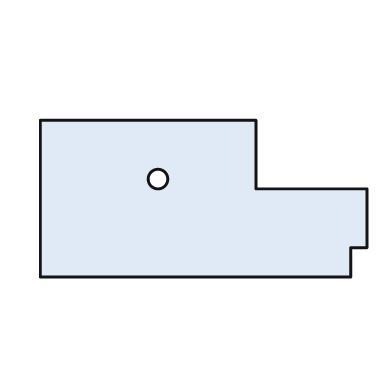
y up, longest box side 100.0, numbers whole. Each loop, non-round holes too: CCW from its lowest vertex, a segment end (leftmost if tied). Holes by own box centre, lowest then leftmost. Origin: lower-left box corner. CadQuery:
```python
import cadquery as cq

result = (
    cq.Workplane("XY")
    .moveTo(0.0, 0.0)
    .lineTo(95.0, 0.0)
    .lineTo(95.0, 9.0)
    .lineTo(100.0, 9.0)
    .lineTo(100.0, 27.0)
    .lineTo(66.0, 27.0)
    .lineTo(66.0, 48.0)
    .lineTo(0.0, 48.0)
    .close()
    .moveTo(36.0, 30.0)
    .circle(3.0)
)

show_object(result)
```